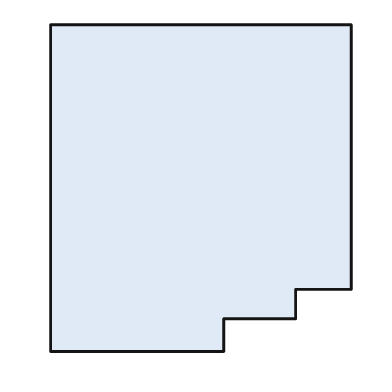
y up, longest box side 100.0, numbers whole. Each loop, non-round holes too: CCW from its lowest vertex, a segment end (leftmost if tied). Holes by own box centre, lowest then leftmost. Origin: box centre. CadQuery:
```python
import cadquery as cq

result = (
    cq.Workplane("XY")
    .moveTo(-46.0, -50.0)
    .lineTo(7.0, -50.0)
    .lineTo(7.0, -40.0)
    .lineTo(29.0, -40.0)
    .lineTo(29.0, -31.0)
    .lineTo(46.0, -31.0)
    .lineTo(46.0, 50.0)
    .lineTo(-46.0, 50.0)
    .close()
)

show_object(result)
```